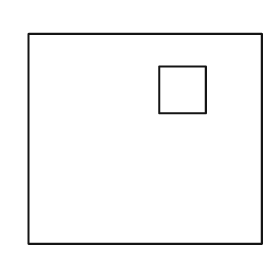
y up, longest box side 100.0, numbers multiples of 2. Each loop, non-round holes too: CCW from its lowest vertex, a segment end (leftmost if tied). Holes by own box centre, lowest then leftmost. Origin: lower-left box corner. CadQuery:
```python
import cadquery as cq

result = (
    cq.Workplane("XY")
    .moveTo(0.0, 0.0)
    .lineTo(100.0, 0.0)
    .lineTo(100.0, 90.0)
    .lineTo(0.0, 90.0)
    .close()
    .moveTo(56.0, 56.0)
    .lineTo(76.0, 56.0)
    .lineTo(76.0, 76.0)
    .lineTo(56.0, 76.0)
    .close()
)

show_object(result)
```